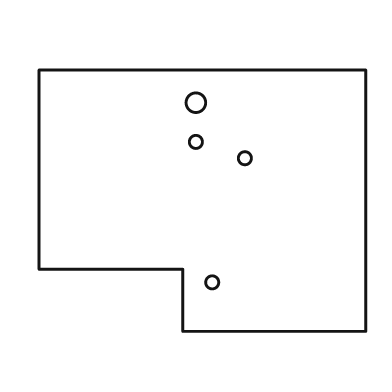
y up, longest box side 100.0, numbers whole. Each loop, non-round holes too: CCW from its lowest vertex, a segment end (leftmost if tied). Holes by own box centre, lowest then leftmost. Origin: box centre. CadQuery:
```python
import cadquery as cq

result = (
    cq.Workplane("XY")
    .moveTo(-6.0, -40.0)
    .lineTo(50.0, -40.0)
    .lineTo(50.0, 40.0)
    .lineTo(-50.0, 40.0)
    .lineTo(-50.0, -21.0)
    .lineTo(-6.0, -21.0)
    .close()
    .moveTo(3.0, -25.0)
    .circle(2.0)
    .moveTo(13.0, 13.0)
    .circle(2.0)
    .moveTo(-2.0, 18.0)
    .circle(2.0)
    .moveTo(-2.0, 30.0)
    .circle(3.0)
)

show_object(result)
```